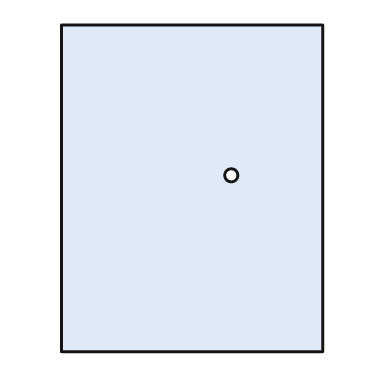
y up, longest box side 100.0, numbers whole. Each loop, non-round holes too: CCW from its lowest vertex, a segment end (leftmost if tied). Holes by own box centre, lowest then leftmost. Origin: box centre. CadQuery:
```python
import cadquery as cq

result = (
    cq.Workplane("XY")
    .moveTo(-40.0, -50.0)
    .lineTo(40.0, -50.0)
    .lineTo(40.0, 50.0)
    .lineTo(-40.0, 50.0)
    .close()
    .moveTo(12.0, 4.0)
    .circle(2.0)
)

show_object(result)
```